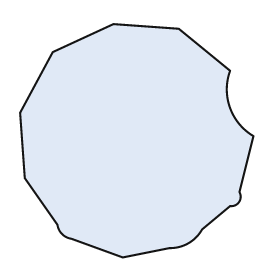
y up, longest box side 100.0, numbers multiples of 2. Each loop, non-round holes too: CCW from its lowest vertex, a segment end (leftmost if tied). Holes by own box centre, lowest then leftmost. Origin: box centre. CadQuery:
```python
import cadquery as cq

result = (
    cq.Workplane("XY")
    .moveTo(-6.0, -50.0)
    .lineTo(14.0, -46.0)
    .threePointArc((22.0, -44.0), (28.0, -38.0))
    .lineTo(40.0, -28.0)
    .threePointArc((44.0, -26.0), (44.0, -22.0))
    .lineTo(50.0, 2.0)
    .threePointArc((40.0, 14.0), (40.0, 30.0))
    .lineTo(18.0, 48.0)
    .lineTo(-10.0, 50.0)
    .lineTo(-36.0, 38.0)
    .lineTo(-50.0, 12.0)
    .lineTo(-48.0, -16.0)
    .lineTo(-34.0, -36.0)
    .threePointArc((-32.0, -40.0), (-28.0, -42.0))
    .close()
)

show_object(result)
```